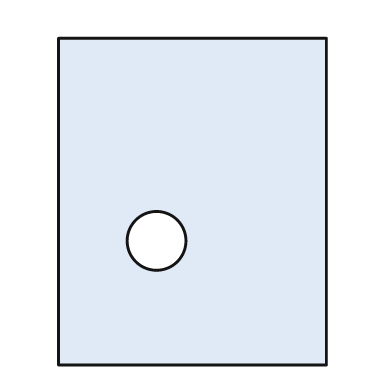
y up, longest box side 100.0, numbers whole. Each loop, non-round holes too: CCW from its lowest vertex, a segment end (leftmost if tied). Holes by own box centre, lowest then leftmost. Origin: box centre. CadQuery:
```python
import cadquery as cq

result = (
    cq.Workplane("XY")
    .moveTo(-41.0, -50.0)
    .lineTo(41.0, -50.0)
    .lineTo(41.0, 50.0)
    .lineTo(-41.0, 50.0)
    .close()
    .moveTo(-11.0, -12.0)
    .circle(9.0)
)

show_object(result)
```